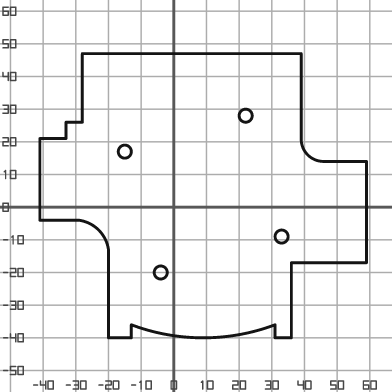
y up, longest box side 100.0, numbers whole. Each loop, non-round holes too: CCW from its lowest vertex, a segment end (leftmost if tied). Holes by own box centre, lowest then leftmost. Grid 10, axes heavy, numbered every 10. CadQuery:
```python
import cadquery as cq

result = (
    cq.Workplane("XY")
    .moveTo(-20.0, -40.0)
    .lineTo(-13.0, -40.0)
    .lineTo(-13.0, -36.0)
    .threePointArc((9.0, -40.0), (31.0, -36.0))
    .lineTo(31.0, -40.0)
    .lineTo(36.0, -40.0)
    .lineTo(36.0, -17.0)
    .lineTo(59.0, -17.0)
    .lineTo(59.0, 14.0)
    .lineTo(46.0, 14.0)
    .threePointArc((41.0, 16.0), (39.0, 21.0))
    .lineTo(39.0, 47.0)
    .lineTo(-28.0, 47.0)
    .lineTo(-28.0, 26.0)
    .lineTo(-33.0, 26.0)
    .lineTo(-33.0, 21.0)
    .lineTo(-41.0, 21.0)
    .lineTo(-41.0, -4.0)
    .lineTo(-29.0, -4.0)
    .threePointArc((-23.0, -7.0), (-20.0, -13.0))
    .close()
    .moveTo(-4.0, -20.0)
    .circle(2.0)
    .moveTo(33.0, -9.0)
    .circle(2.0)
    .moveTo(-15.0, 17.0)
    .circle(2.0)
    .moveTo(22.0, 28.0)
    .circle(2.0)
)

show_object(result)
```